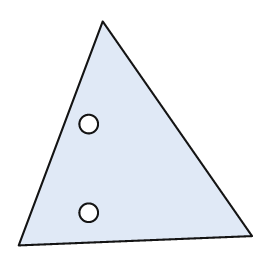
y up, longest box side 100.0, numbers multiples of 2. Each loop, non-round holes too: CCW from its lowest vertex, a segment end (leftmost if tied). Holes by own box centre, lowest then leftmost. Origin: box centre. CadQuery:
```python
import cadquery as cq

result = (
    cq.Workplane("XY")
    .moveTo(-50.0, -48.0)
    .lineTo(50.0, -44.0)
    .lineTo(-14.0, 48.0)
    .close()
    .moveTo(-20.0, -34.0)
    .circle(4.0)
    .moveTo(-20.0, 4.0)
    .circle(4.0)
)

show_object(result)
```